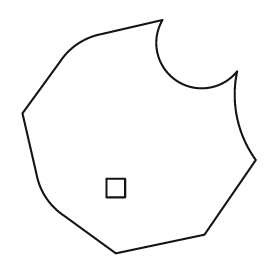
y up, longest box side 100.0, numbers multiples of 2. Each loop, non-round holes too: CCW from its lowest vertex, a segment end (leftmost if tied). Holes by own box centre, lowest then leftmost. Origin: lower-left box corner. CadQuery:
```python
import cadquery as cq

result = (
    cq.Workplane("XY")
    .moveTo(40.0, 0.0)
    .lineTo(78.0, 8.0)
    .lineTo(100.0, 40.0)
    .threePointArc((92.0, 58.0), (92.0, 78.0))
    .threePointArc((66.0, 74.0), (60.0, 100.0))
    .lineTo(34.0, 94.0)
    .threePointArc((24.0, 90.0), (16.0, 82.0))
    .lineTo(0.0, 60.0)
    .lineTo(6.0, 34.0)
    .threePointArc((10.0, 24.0), (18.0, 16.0))
    .close()
    .moveTo(36.0, 24.0)
    .lineTo(44.0, 24.0)
    .lineTo(44.0, 32.0)
    .lineTo(36.0, 32.0)
    .close()
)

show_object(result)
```